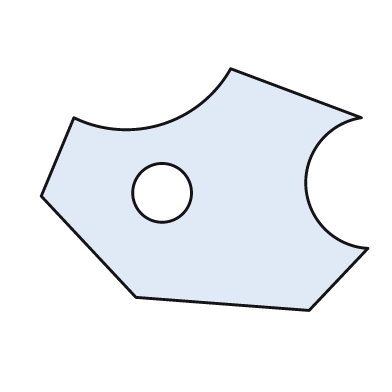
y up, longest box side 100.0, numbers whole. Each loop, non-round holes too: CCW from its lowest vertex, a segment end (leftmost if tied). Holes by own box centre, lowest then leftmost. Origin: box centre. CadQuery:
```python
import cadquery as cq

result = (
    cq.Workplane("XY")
    .moveTo(32.0, -37.0)
    .lineTo(50.0, -18.0)
    .threePointArc((31.0, 1.0), (48.0, 22.0))
    .lineTo(8.0, 37.0)
    .threePointArc((-13.0, 20.0), (-40.0, 22.0))
    .lineTo(-50.0, -2.0)
    .lineTo(-21.0, -33.0)
    .close()
    .moveTo(-13.0, -1.0)
    .circle(9.0)
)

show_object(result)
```